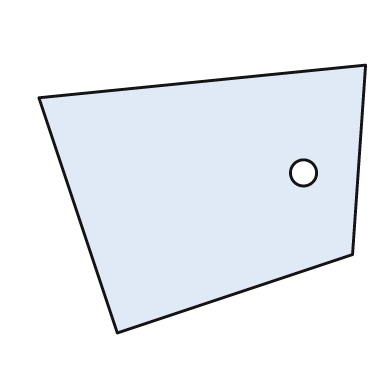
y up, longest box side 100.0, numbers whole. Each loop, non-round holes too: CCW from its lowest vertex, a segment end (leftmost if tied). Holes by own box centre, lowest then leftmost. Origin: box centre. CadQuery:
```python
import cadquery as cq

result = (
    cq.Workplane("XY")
    .moveTo(-26.0, -41.0)
    .lineTo(46.0, -17.0)
    .lineTo(50.0, 41.0)
    .lineTo(-50.0, 31.0)
    .close()
    .moveTo(31.0, 8.0)
    .circle(4.0)
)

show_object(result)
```